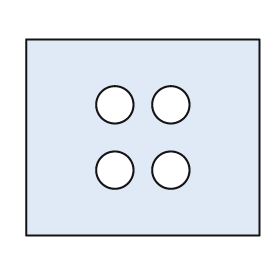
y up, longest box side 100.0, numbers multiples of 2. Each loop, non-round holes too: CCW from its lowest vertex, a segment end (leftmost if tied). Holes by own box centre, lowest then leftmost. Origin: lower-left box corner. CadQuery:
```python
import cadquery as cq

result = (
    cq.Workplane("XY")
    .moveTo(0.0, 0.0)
    .lineTo(100.0, 0.0)
    .lineTo(100.0, 84.0)
    .lineTo(0.0, 84.0)
    .close()
    .moveTo(38.0, 28.0)
    .circle(8.0)
    .moveTo(62.0, 28.0)
    .circle(8.0)
    .moveTo(38.0, 56.0)
    .circle(8.0)
    .moveTo(62.0, 56.0)
    .circle(8.0)
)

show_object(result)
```